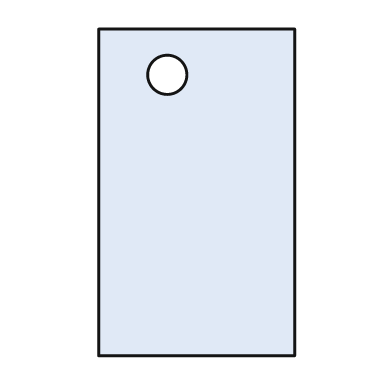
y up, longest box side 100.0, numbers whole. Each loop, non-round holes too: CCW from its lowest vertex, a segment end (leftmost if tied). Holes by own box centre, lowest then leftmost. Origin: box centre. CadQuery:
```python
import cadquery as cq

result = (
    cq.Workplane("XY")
    .moveTo(-30.0, -50.0)
    .lineTo(30.0, -50.0)
    .lineTo(30.0, 50.0)
    .lineTo(-30.0, 50.0)
    .close()
    .moveTo(-9.0, 36.0)
    .circle(6.0)
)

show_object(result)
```